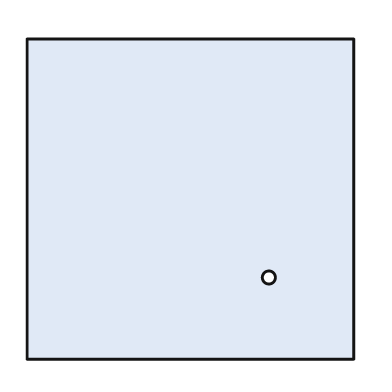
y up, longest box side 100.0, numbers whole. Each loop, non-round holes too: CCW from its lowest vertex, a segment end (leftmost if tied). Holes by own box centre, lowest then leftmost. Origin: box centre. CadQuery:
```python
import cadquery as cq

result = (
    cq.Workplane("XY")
    .moveTo(-50.0, -49.0)
    .lineTo(50.0, -49.0)
    .lineTo(50.0, 49.0)
    .lineTo(-50.0, 49.0)
    .close()
    .moveTo(24.0, -24.0)
    .circle(2.0)
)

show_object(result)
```